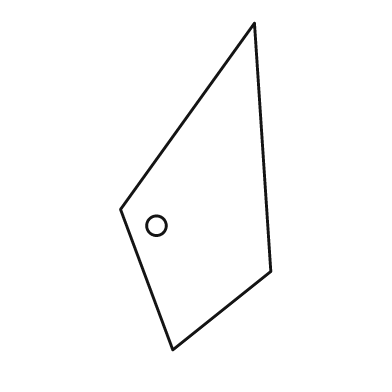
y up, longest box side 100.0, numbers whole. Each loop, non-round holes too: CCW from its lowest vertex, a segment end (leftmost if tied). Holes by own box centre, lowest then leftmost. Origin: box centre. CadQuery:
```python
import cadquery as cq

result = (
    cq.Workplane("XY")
    .moveTo(-7.0, -50.0)
    .lineTo(23.0, -26.0)
    .lineTo(18.0, 50.0)
    .lineTo(-23.0, -7.0)
    .close()
    .moveTo(-12.0, -12.0)
    .circle(3.0)
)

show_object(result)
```